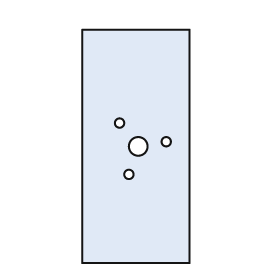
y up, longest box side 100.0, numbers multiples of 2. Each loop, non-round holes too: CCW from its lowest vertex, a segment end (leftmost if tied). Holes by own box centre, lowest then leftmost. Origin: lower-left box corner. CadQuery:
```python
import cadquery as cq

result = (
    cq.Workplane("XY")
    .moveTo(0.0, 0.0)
    .lineTo(46.0, 0.0)
    .lineTo(46.0, 100.0)
    .lineTo(0.0, 100.0)
    .close()
    .moveTo(20.0, 38.0)
    .circle(2.0)
    .moveTo(24.0, 50.0)
    .circle(4.0)
    .moveTo(36.0, 52.0)
    .circle(2.0)
    .moveTo(16.0, 60.0)
    .circle(2.0)
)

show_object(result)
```